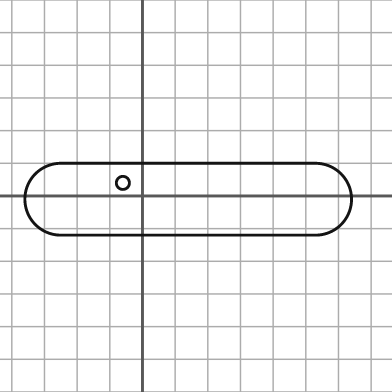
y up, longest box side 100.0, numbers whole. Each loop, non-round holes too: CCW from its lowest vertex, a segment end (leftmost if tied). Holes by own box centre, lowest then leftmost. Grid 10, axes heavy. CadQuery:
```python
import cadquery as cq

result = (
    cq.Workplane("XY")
    .moveTo(-25.0, -12.0)
    .lineTo(53.0, -12.0)
    .threePointArc((64.0, -1.0), (53.0, 10.0))
    .lineTo(-25.0, 10.0)
    .threePointArc((-36.0, -1.0), (-25.0, -12.0))
    .close()
    .moveTo(-6.0, 4.0)
    .circle(2.0)
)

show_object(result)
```